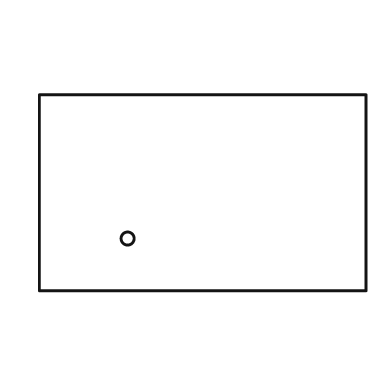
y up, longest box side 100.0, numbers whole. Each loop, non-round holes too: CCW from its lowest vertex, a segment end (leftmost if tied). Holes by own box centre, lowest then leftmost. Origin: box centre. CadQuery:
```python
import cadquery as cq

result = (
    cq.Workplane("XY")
    .moveTo(-50.0, -30.0)
    .lineTo(50.0, -30.0)
    .lineTo(50.0, 30.0)
    .lineTo(-50.0, 30.0)
    .close()
    .moveTo(-23.0, -14.0)
    .circle(2.0)
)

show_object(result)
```